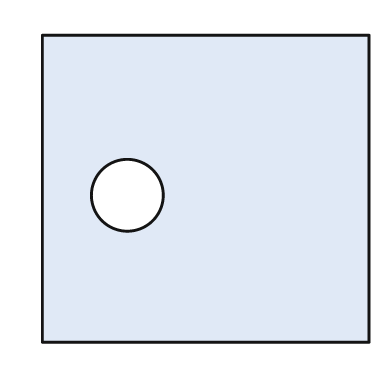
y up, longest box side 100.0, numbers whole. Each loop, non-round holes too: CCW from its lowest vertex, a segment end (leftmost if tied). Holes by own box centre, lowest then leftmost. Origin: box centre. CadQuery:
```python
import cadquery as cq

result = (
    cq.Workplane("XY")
    .moveTo(-50.0, -47.0)
    .lineTo(50.0, -47.0)
    .lineTo(50.0, 47.0)
    .lineTo(-50.0, 47.0)
    .close()
    .moveTo(-24.0, -2.0)
    .circle(11.0)
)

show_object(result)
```